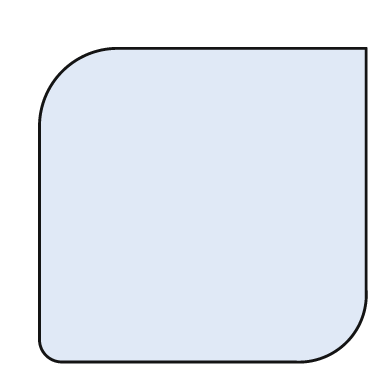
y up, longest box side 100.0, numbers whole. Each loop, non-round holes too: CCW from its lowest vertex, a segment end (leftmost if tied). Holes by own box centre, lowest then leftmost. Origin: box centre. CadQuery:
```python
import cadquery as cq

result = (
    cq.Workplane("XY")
    .moveTo(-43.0, -48.0)
    .lineTo(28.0, -48.0)
    .threePointArc((44.0, -42.0), (50.0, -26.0))
    .lineTo(50.0, 48.0)
    .lineTo(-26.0, 48.0)
    .threePointArc((-43.0, 41.0), (-50.0, 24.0))
    .lineTo(-50.0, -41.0)
    .threePointArc((-48.0, -46.0), (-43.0, -48.0))
    .close()
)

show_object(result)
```